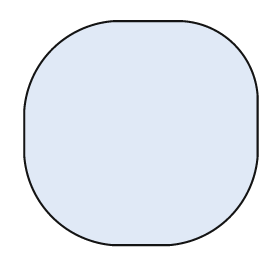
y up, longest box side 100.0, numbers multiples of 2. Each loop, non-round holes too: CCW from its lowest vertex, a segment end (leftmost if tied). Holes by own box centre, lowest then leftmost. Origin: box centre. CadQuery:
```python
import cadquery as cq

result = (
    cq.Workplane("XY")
    .moveTo(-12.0, -48.0)
    .lineTo(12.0, -48.0)
    .threePointArc((38.0, -36.0), (50.0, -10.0))
    .lineTo(50.0, 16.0)
    .threePointArc((40.0, 38.0), (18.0, 48.0))
    .lineTo(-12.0, 48.0)
    .threePointArc((-38.0, 36.0), (-50.0, 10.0))
    .lineTo(-50.0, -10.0)
    .threePointArc((-38.0, -36.0), (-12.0, -48.0))
    .close()
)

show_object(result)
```